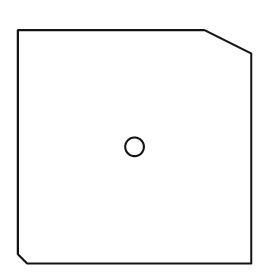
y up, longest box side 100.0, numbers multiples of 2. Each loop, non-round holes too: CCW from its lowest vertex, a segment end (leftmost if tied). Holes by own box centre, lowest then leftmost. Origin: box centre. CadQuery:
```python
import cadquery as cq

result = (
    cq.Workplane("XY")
    .moveTo(-46.0, -50.0)
    .lineTo(50.0, -50.0)
    .lineTo(50.0, 40.0)
    .lineTo(30.0, 50.0)
    .lineTo(-50.0, 50.0)
    .lineTo(-50.0, -46.0)
    .close()
    .moveTo(0.0, 0.0)
    .circle(4.0)
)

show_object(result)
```